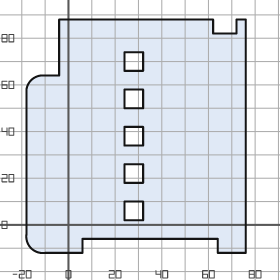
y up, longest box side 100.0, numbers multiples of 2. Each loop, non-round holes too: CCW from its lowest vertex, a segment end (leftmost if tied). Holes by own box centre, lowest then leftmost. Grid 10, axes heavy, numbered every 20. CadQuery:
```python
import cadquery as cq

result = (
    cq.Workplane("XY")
    .moveTo(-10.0, -12.0)
    .lineTo(6.0, -12.0)
    .lineTo(6.0, -6.0)
    .lineTo(64.0, -6.0)
    .lineTo(64.0, -12.0)
    .lineTo(76.0, -12.0)
    .lineTo(76.0, 88.0)
    .lineTo(72.0, 88.0)
    .lineTo(72.0, 82.0)
    .lineTo(62.0, 82.0)
    .lineTo(62.0, 88.0)
    .lineTo(-4.0, 88.0)
    .lineTo(-4.0, 64.0)
    .lineTo(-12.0, 64.0)
    .threePointArc((-16.0, 62.0), (-18.0, 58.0))
    .lineTo(-18.0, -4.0)
    .threePointArc((-16.0, -10.0), (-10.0, -12.0))
    .close()
    .moveTo(24.0, 2.0)
    .lineTo(32.0, 2.0)
    .lineTo(32.0, 10.0)
    .lineTo(24.0, 10.0)
    .close()
    .moveTo(24.0, 18.0)
    .lineTo(32.0, 18.0)
    .lineTo(32.0, 26.0)
    .lineTo(24.0, 26.0)
    .close()
    .moveTo(24.0, 34.0)
    .lineTo(32.0, 34.0)
    .lineTo(32.0, 42.0)
    .lineTo(24.0, 42.0)
    .close()
    .moveTo(24.0, 50.0)
    .lineTo(32.0, 50.0)
    .lineTo(32.0, 58.0)
    .lineTo(24.0, 58.0)
    .close()
    .moveTo(24.0, 66.0)
    .lineTo(32.0, 66.0)
    .lineTo(32.0, 74.0)
    .lineTo(24.0, 74.0)
    .close()
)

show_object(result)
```